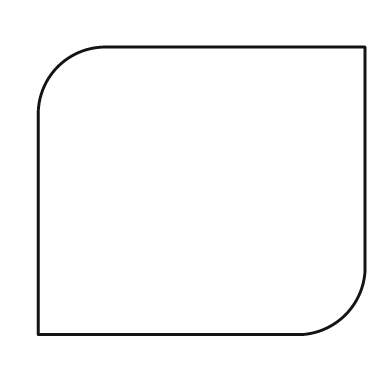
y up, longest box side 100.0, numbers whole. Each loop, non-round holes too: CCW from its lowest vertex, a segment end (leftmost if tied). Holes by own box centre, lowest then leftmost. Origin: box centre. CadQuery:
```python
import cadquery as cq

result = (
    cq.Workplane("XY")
    .moveTo(-50.0, -44.0)
    .lineTo(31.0, -44.0)
    .threePointArc((44.0, -38.0), (50.0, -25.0))
    .lineTo(50.0, 44.0)
    .lineTo(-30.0, 44.0)
    .threePointArc((-44.0, 38.0), (-50.0, 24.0))
    .close()
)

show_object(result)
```